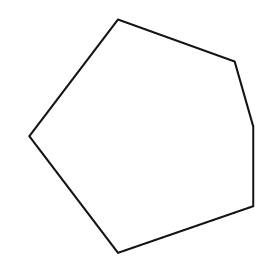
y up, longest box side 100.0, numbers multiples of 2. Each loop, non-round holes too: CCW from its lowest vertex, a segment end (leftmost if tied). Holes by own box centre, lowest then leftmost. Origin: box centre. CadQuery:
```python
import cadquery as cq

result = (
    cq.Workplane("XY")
    .moveTo(-10.0, -50.0)
    .lineTo(48.0, -30.0)
    .lineTo(48.0, 4.0)
    .lineTo(40.0, 32.0)
    .lineTo(-10.0, 50.0)
    .lineTo(-48.0, 0.0)
    .close()
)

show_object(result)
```